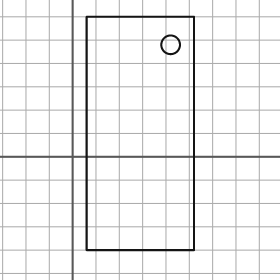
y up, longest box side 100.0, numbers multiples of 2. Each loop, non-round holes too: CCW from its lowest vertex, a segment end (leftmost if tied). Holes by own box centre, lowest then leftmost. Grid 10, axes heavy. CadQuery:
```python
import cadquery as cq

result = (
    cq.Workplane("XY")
    .moveTo(6.0, -40.0)
    .lineTo(52.0, -40.0)
    .lineTo(52.0, 60.0)
    .lineTo(6.0, 60.0)
    .close()
    .moveTo(42.0, 48.0)
    .circle(4.0)
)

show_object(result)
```